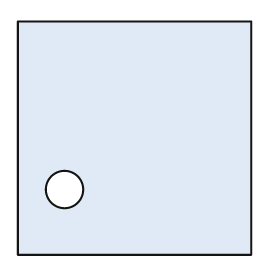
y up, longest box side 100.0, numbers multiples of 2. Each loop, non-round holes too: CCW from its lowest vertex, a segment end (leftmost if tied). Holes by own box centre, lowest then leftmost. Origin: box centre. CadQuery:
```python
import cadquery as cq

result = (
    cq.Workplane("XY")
    .moveTo(-50.0, -50.0)
    .lineTo(50.0, -50.0)
    .lineTo(50.0, 50.0)
    .lineTo(-50.0, 50.0)
    .close()
    .moveTo(-30.0, -22.0)
    .circle(8.0)
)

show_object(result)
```